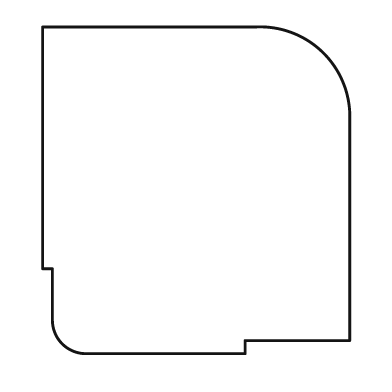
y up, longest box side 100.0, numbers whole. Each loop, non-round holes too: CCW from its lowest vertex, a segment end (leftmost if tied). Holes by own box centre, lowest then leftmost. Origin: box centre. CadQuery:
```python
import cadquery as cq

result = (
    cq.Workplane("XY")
    .moveTo(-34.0, -50.0)
    .lineTo(15.0, -50.0)
    .lineTo(15.0, -46.0)
    .lineTo(47.0, -46.0)
    .lineTo(47.0, 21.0)
    .threePointArc((39.0, 42.0), (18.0, 50.0))
    .lineTo(-47.0, 50.0)
    .lineTo(-47.0, -24.0)
    .lineTo(-44.0, -24.0)
    .lineTo(-44.0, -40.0)
    .threePointArc((-41.0, -47.0), (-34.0, -50.0))
    .close()
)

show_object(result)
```